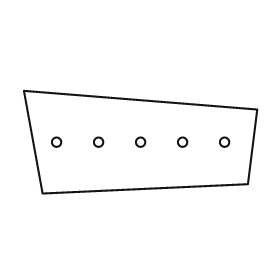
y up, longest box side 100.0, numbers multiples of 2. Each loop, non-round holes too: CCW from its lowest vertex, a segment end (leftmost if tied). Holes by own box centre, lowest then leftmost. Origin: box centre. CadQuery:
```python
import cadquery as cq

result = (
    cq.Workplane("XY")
    .moveTo(-42.0, -22.0)
    .lineTo(46.0, -18.0)
    .lineTo(50.0, 14.0)
    .lineTo(-50.0, 22.0)
    .close()
    .moveTo(-36.0, 0.0)
    .circle(2.0)
    .moveTo(-18.0, 0.0)
    .circle(2.0)
    .moveTo(0.0, 0.0)
    .circle(2.0)
    .moveTo(18.0, 0.0)
    .circle(2.0)
    .moveTo(36.0, 0.0)
    .circle(2.0)
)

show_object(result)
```